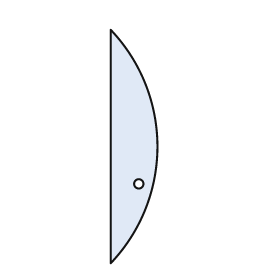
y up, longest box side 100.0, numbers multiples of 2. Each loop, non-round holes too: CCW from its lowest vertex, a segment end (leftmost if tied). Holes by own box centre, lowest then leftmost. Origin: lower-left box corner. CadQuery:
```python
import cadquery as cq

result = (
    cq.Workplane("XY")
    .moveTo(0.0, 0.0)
    .threePointArc((20.0, 50.0), (0.0, 100.0))
    .close()
    .moveTo(12.0, 34.0)
    .circle(2.0)
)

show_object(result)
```